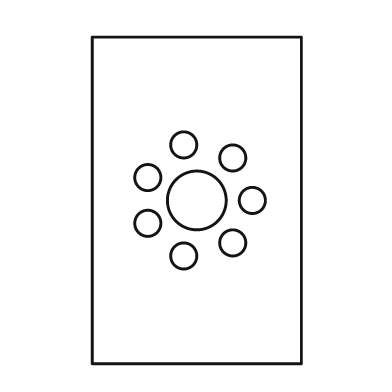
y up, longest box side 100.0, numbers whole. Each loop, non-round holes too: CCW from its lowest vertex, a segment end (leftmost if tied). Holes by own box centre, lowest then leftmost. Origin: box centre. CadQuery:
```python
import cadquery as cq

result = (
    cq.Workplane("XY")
    .moveTo(-32.0, -50.0)
    .lineTo(32.0, -50.0)
    .lineTo(32.0, 50.0)
    .lineTo(-32.0, 50.0)
    .close()
    .moveTo(-4.0, -17.0)
    .circle(4.0)
    .moveTo(11.0, -13.0)
    .circle(4.0)
    .moveTo(-15.0, -7.0)
    .circle(4.0)
    .moveTo(0.0, 0.0)
    .circle(9.0)
    .moveTo(17.0, 0.0)
    .circle(4.0)
    .moveTo(-15.0, 7.0)
    .circle(4.0)
    .moveTo(11.0, 13.0)
    .circle(4.0)
    .moveTo(-4.0, 17.0)
    .circle(4.0)
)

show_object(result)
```